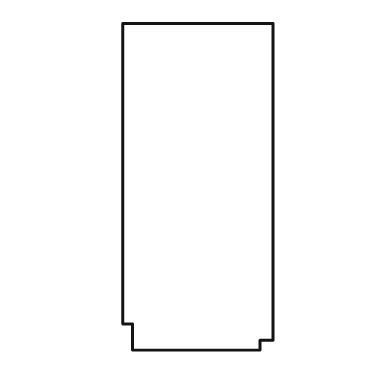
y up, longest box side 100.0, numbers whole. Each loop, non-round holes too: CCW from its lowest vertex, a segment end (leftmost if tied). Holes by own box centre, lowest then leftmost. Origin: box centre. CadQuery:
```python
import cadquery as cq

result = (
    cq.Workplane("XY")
    .moveTo(-20.0, -50.0)
    .lineTo(19.0, -50.0)
    .lineTo(19.0, -47.0)
    .lineTo(23.0, -47.0)
    .lineTo(23.0, 50.0)
    .lineTo(-23.0, 50.0)
    .lineTo(-23.0, -42.0)
    .lineTo(-20.0, -42.0)
    .close()
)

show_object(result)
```